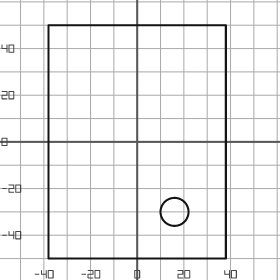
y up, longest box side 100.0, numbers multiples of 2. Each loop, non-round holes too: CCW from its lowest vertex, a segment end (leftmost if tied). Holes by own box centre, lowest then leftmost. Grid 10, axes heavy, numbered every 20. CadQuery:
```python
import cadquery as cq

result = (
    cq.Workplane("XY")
    .moveTo(-38.0, -50.0)
    .lineTo(38.0, -50.0)
    .lineTo(38.0, 50.0)
    .lineTo(-38.0, 50.0)
    .close()
    .moveTo(16.0, -30.0)
    .circle(6.0)
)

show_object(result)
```